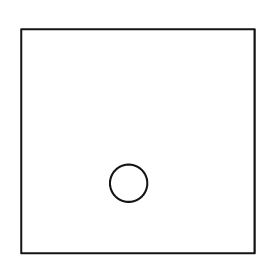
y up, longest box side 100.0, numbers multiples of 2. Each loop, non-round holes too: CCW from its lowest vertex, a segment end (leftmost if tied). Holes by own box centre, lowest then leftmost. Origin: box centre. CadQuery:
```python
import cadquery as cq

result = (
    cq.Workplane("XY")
    .moveTo(-50.0, -48.0)
    .lineTo(50.0, -48.0)
    .lineTo(50.0, 48.0)
    .lineTo(-50.0, 48.0)
    .close()
    .moveTo(-4.0, -18.0)
    .circle(8.0)
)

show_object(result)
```